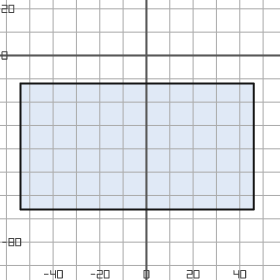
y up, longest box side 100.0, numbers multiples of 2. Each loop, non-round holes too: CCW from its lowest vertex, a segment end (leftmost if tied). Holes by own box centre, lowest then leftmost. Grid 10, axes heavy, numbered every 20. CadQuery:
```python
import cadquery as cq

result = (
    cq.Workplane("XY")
    .moveTo(-54.0, -66.0)
    .lineTo(46.0, -66.0)
    .lineTo(46.0, -12.0)
    .lineTo(-54.0, -12.0)
    .close()
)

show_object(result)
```